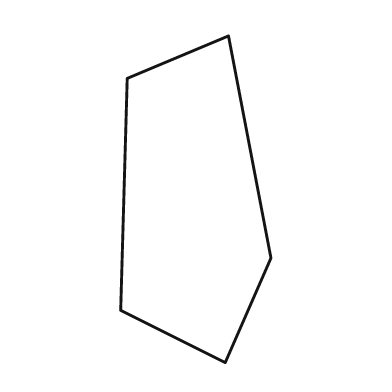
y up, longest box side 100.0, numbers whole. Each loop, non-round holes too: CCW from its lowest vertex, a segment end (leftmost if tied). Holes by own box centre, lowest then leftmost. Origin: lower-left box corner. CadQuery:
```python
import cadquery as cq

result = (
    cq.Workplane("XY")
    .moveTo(32.0, 0.0)
    .lineTo(46.0, 32.0)
    .lineTo(33.0, 100.0)
    .lineTo(2.0, 87.0)
    .lineTo(0.0, 16.0)
    .close()
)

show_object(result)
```